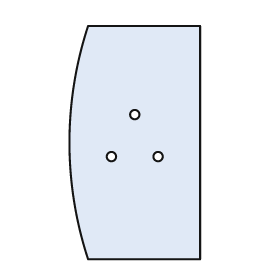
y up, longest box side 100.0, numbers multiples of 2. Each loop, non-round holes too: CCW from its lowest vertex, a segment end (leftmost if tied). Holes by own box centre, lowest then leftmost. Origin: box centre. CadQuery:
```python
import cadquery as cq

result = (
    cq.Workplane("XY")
    .moveTo(-20.0, -50.0)
    .lineTo(28.0, -50.0)
    .lineTo(28.0, 50.0)
    .lineTo(-20.0, 50.0)
    .threePointArc((-28.0, 0.0), (-20.0, -50.0))
    .close()
    .moveTo(-10.0, -6.0)
    .circle(2.0)
    .moveTo(10.0, -6.0)
    .circle(2.0)
    .moveTo(0.0, 12.0)
    .circle(2.0)
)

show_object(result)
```